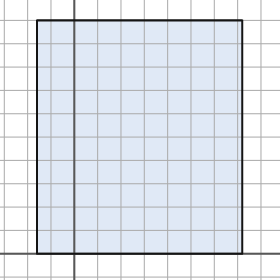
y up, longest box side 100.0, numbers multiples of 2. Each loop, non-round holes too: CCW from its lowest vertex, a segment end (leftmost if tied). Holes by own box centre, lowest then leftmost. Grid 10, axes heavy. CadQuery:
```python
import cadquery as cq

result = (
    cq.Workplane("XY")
    .moveTo(-16.0, 0.0)
    .lineTo(72.0, 0.0)
    .lineTo(72.0, 100.0)
    .lineTo(-16.0, 100.0)
    .close()
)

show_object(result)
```